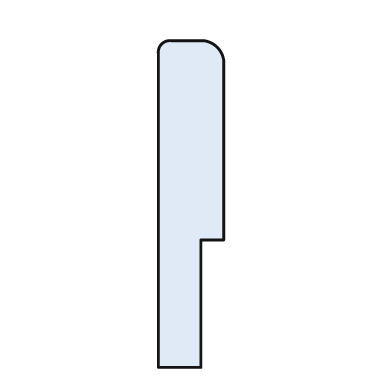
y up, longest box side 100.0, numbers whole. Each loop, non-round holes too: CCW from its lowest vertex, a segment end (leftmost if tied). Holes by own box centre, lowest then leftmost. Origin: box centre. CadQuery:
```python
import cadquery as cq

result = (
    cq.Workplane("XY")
    .moveTo(-10.0, -50.0)
    .lineTo(3.0, -50.0)
    .lineTo(3.0, -11.0)
    .lineTo(10.0, -11.0)
    .lineTo(10.0, 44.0)
    .threePointArc((8.0, 48.0), (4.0, 50.0))
    .lineTo(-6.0, 50.0)
    .threePointArc((-9.0, 49.0), (-10.0, 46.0))
    .close()
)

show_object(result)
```